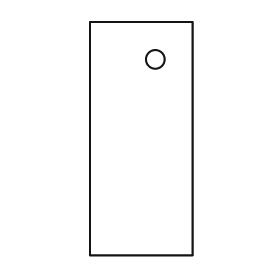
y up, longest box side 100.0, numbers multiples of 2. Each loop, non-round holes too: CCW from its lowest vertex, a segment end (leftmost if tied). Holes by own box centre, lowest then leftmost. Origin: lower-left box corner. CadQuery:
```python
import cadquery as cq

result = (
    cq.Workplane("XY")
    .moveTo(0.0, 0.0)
    .lineTo(44.0, 0.0)
    .lineTo(44.0, 100.0)
    .lineTo(0.0, 100.0)
    .close()
    .moveTo(28.0, 84.0)
    .circle(4.0)
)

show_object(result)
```